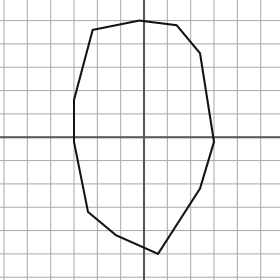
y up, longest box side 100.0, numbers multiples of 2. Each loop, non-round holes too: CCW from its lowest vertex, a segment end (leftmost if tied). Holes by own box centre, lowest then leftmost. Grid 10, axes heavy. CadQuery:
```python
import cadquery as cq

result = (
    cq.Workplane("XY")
    .moveTo(6.0, -50.0)
    .lineTo(24.0, -22.0)
    .lineTo(30.0, -2.0)
    .lineTo(24.0, 36.0)
    .lineTo(14.0, 48.0)
    .lineTo(-2.0, 50.0)
    .lineTo(-22.0, 46.0)
    .lineTo(-30.0, 16.0)
    .lineTo(-30.0, -2.0)
    .lineTo(-24.0, -32.0)
    .lineTo(-12.0, -42.0)
    .close()
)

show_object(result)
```